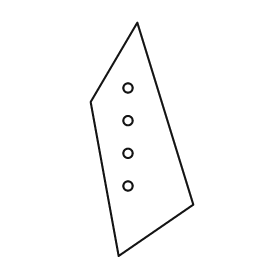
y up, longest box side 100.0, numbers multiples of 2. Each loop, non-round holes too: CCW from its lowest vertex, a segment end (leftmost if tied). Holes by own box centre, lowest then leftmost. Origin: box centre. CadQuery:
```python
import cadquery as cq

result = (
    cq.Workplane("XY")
    .moveTo(-10.0, -50.0)
    .lineTo(22.0, -28.0)
    .lineTo(-2.0, 50.0)
    .lineTo(-22.0, 16.0)
    .close()
    .moveTo(-6.0, -20.0)
    .circle(2.0)
    .moveTo(-6.0, -6.0)
    .circle(2.0)
    .moveTo(-6.0, 8.0)
    .circle(2.0)
    .moveTo(-6.0, 22.0)
    .circle(2.0)
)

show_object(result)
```